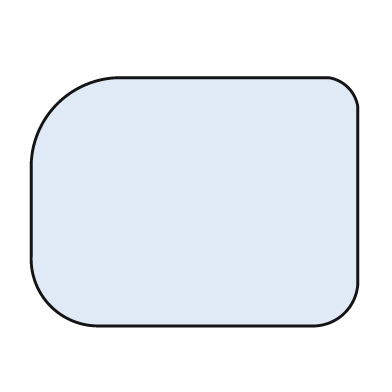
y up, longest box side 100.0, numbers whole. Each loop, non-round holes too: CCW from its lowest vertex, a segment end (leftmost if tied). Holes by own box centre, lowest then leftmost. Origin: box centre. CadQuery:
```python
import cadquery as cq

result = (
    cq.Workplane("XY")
    .moveTo(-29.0, -38.0)
    .lineTo(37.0, -38.0)
    .threePointArc((46.0, -34.0), (50.0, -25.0))
    .lineTo(50.0, 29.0)
    .threePointArc((47.0, 35.0), (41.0, 38.0))
    .lineTo(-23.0, 38.0)
    .threePointArc((-42.0, 30.0), (-50.0, 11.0))
    .lineTo(-50.0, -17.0)
    .threePointArc((-44.0, -32.0), (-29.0, -38.0))
    .close()
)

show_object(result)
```